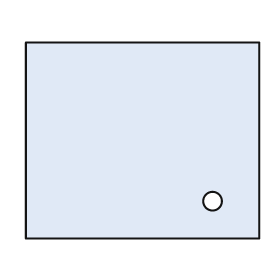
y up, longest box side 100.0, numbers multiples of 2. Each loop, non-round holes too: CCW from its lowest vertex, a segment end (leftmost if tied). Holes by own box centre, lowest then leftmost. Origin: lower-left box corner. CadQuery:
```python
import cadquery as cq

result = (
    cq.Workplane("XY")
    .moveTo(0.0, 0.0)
    .lineTo(100.0, 0.0)
    .lineTo(100.0, 84.0)
    .lineTo(0.0, 84.0)
    .close()
    .moveTo(80.0, 16.0)
    .circle(4.0)
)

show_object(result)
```